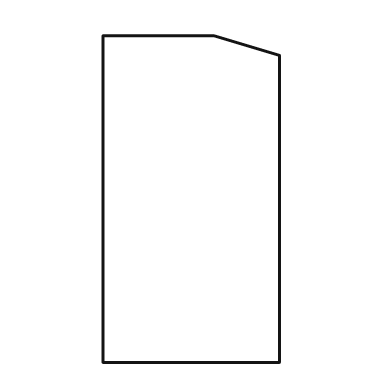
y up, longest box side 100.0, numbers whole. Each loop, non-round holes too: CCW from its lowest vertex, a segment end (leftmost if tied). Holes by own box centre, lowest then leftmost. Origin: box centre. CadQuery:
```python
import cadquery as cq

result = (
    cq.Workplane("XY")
    .moveTo(-27.0, -50.0)
    .lineTo(27.0, -50.0)
    .lineTo(27.0, 44.0)
    .lineTo(7.0, 50.0)
    .lineTo(-27.0, 50.0)
    .close()
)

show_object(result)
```